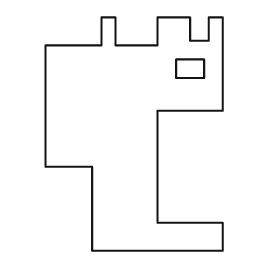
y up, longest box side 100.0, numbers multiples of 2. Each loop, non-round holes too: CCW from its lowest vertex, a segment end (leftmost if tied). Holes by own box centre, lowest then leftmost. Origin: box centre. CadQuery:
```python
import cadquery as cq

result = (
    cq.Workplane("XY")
    .moveTo(-18.0, -50.0)
    .lineTo(38.0, -50.0)
    .lineTo(38.0, -38.0)
    .lineTo(10.0, -38.0)
    .lineTo(10.0, 10.0)
    .lineTo(38.0, 10.0)
    .lineTo(38.0, 50.0)
    .lineTo(32.0, 50.0)
    .lineTo(32.0, 40.0)
    .lineTo(24.0, 40.0)
    .lineTo(24.0, 50.0)
    .lineTo(10.0, 50.0)
    .lineTo(10.0, 38.0)
    .lineTo(-8.0, 38.0)
    .lineTo(-8.0, 50.0)
    .lineTo(-14.0, 50.0)
    .lineTo(-14.0, 38.0)
    .lineTo(-38.0, 38.0)
    .lineTo(-38.0, -14.0)
    .lineTo(-18.0, -14.0)
    .close()
    .moveTo(18.0, 24.0)
    .lineTo(30.0, 24.0)
    .lineTo(30.0, 32.0)
    .lineTo(18.0, 32.0)
    .close()
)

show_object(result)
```